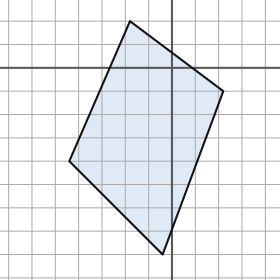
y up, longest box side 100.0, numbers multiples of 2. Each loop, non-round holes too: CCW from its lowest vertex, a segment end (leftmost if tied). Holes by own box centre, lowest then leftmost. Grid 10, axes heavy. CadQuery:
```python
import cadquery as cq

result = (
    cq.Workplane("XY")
    .moveTo(-4.0, -80.0)
    .lineTo(22.0, -10.0)
    .lineTo(-18.0, 20.0)
    .lineTo(-44.0, -40.0)
    .close()
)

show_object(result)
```